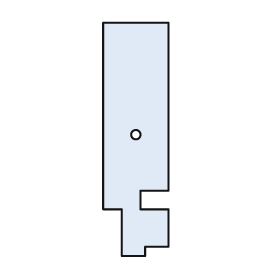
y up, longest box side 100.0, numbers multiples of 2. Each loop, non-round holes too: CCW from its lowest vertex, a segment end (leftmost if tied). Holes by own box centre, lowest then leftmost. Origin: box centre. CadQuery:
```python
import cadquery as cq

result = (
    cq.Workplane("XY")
    .moveTo(-6.0, -50.0)
    .lineTo(4.0, -50.0)
    .lineTo(4.0, -46.0)
    .lineTo(14.0, -46.0)
    .lineTo(14.0, -30.0)
    .lineTo(2.0, -30.0)
    .lineTo(2.0, -22.0)
    .lineTo(14.0, -22.0)
    .lineTo(14.0, 50.0)
    .lineTo(-14.0, 50.0)
    .lineTo(-14.0, -30.0)
    .lineTo(-6.0, -30.0)
    .close()
    .moveTo(0.0, 2.0)
    .circle(2.0)
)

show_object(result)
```